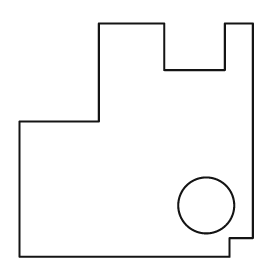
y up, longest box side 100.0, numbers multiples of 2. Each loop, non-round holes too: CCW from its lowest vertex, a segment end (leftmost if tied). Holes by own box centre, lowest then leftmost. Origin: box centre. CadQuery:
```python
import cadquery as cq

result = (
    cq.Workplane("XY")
    .moveTo(-50.0, -50.0)
    .lineTo(40.0, -50.0)
    .lineTo(40.0, -42.0)
    .lineTo(50.0, -42.0)
    .lineTo(50.0, 50.0)
    .lineTo(38.0, 50.0)
    .lineTo(38.0, 30.0)
    .lineTo(12.0, 30.0)
    .lineTo(12.0, 50.0)
    .lineTo(-16.0, 50.0)
    .lineTo(-16.0, 8.0)
    .lineTo(-50.0, 8.0)
    .close()
    .moveTo(30.0, -28.0)
    .circle(12.0)
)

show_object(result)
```